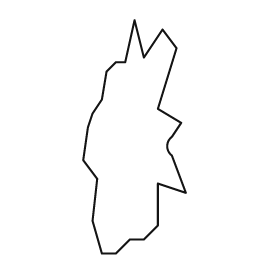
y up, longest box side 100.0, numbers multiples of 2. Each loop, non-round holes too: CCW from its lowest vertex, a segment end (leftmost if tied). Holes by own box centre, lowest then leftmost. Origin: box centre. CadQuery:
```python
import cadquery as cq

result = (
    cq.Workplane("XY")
    .moveTo(-14.0, -50.0)
    .lineTo(-8.0, -50.0)
    .lineTo(-2.0, -44.0)
    .lineTo(4.0, -44.0)
    .lineTo(10.0, -38.0)
    .lineTo(10.0, -20.0)
    .lineTo(22.0, -24.0)
    .lineTo(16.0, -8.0)
    .threePointArc((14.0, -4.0), (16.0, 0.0))
    .lineTo(20.0, 6.0)
    .lineTo(10.0, 12.0)
    .lineTo(18.0, 38.0)
    .lineTo(12.0, 46.0)
    .lineTo(4.0, 34.0)
    .lineTo(0.0, 50.0)
    .lineTo(-4.0, 32.0)
    .lineTo(-8.0, 32.0)
    .lineTo(-12.0, 28.0)
    .lineTo(-14.0, 16.0)
    .lineTo(-18.0, 10.0)
    .lineTo(-20.0, 4.0)
    .lineTo(-22.0, -10.0)
    .lineTo(-16.0, -18.0)
    .lineTo(-18.0, -36.0)
    .close()
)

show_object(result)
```